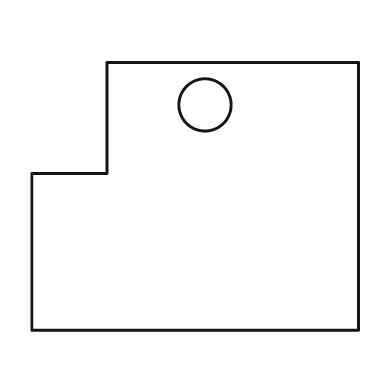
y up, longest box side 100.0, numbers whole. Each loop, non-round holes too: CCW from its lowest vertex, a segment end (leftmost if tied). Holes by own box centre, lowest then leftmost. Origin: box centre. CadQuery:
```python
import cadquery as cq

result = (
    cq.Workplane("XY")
    .moveTo(-50.0, -41.0)
    .lineTo(50.0, -41.0)
    .lineTo(50.0, 41.0)
    .lineTo(-27.0, 41.0)
    .lineTo(-27.0, 7.0)
    .lineTo(-50.0, 7.0)
    .close()
    .moveTo(3.0, 28.0)
    .circle(8.0)
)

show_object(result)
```